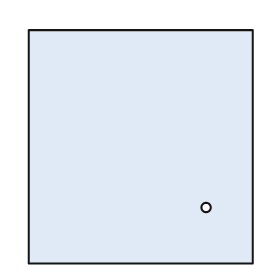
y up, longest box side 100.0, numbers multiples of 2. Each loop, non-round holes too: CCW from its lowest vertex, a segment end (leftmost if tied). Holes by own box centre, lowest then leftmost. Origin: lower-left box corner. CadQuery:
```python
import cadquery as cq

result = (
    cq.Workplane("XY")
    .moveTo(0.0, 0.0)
    .lineTo(96.0, 0.0)
    .lineTo(96.0, 100.0)
    .lineTo(0.0, 100.0)
    .close()
    .moveTo(76.0, 24.0)
    .circle(2.0)
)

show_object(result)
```